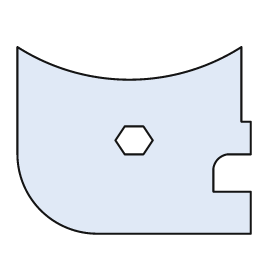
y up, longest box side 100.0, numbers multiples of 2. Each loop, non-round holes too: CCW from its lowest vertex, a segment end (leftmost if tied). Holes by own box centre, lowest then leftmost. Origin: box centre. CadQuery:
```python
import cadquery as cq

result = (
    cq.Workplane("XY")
    .moveTo(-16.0, -40.0)
    .lineTo(50.0, -40.0)
    .lineTo(50.0, -22.0)
    .lineTo(34.0, -22.0)
    .lineTo(34.0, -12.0)
    .threePointArc((36.0, -8.0), (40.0, -6.0))
    .lineTo(50.0, -6.0)
    .lineTo(50.0, 8.0)
    .lineTo(46.0, 8.0)
    .lineTo(46.0, 40.0)
    .threePointArc((-2.0, 26.0), (-50.0, 40.0))
    .lineTo(-50.0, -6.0)
    .threePointArc((-40.0, -30.0), (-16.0, -40.0))
    .close()
    .moveTo(-4.0, -6.0)
    .lineTo(4.0, -6.0)
    .lineTo(8.0, 0.0)
    .lineTo(4.0, 6.0)
    .lineTo(-4.0, 6.0)
    .lineTo(-8.0, 0.0)
    .close()
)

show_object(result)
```